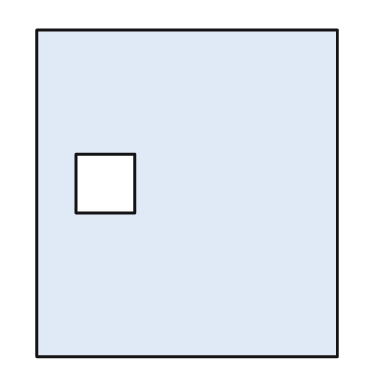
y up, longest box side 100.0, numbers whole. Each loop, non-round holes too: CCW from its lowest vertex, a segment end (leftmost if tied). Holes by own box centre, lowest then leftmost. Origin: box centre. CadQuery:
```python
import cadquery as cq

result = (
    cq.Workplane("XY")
    .moveTo(-46.0, -50.0)
    .lineTo(46.0, -50.0)
    .lineTo(46.0, 50.0)
    .lineTo(-46.0, 50.0)
    .close()
    .moveTo(-34.0, -6.0)
    .lineTo(-16.0, -6.0)
    .lineTo(-16.0, 12.0)
    .lineTo(-34.0, 12.0)
    .close()
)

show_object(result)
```